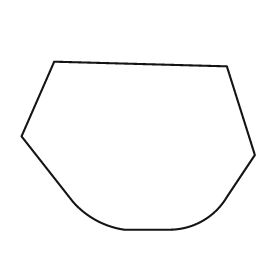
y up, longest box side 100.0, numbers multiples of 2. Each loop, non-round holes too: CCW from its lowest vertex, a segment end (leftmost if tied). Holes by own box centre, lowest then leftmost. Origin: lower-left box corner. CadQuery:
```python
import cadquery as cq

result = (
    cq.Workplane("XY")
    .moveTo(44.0, 0.0)
    .lineTo(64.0, 0.0)
    .threePointArc((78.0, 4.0), (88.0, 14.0))
    .lineTo(100.0, 32.0)
    .lineTo(88.0, 70.0)
    .lineTo(14.0, 72.0)
    .lineTo(0.0, 40.0)
    .lineTo(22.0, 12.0)
    .threePointArc((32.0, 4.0), (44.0, 0.0))
    .close()
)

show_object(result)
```